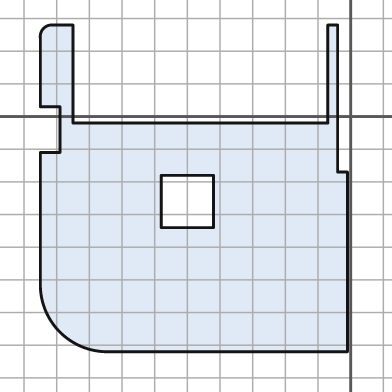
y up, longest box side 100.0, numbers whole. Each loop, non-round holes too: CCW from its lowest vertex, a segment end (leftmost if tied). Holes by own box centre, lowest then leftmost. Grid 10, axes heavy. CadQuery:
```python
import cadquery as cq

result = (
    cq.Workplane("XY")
    .moveTo(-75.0, -72.0)
    .lineTo(-1.0, -72.0)
    .lineTo(-1.0, -17.0)
    .lineTo(-4.0, -17.0)
    .lineTo(-4.0, 28.0)
    .lineTo(-7.0, 28.0)
    .lineTo(-7.0, -2.0)
    .lineTo(-85.0, -2.0)
    .lineTo(-85.0, 28.0)
    .lineTo(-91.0, 28.0)
    .threePointArc((-94.0, 27.0), (-95.0, 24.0))
    .lineTo(-95.0, 3.0)
    .lineTo(-89.0, 3.0)
    .lineTo(-89.0, -11.0)
    .lineTo(-95.0, -11.0)
    .lineTo(-95.0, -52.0)
    .threePointArc((-89.0, -66.0), (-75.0, -72.0))
    .close()
    .moveTo(-58.0, -34.0)
    .lineTo(-42.0, -34.0)
    .lineTo(-42.0, -18.0)
    .lineTo(-58.0, -18.0)
    .close()
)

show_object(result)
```